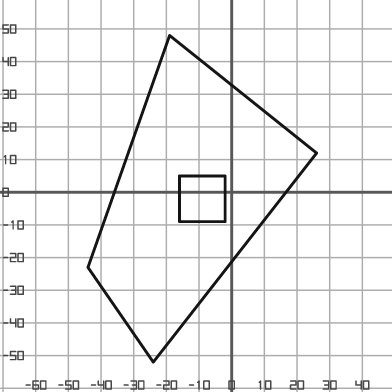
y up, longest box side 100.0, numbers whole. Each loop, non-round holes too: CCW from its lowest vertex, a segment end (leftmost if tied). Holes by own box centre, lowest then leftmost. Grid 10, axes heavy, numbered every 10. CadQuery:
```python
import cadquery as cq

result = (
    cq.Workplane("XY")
    .moveTo(-24.0, -52.0)
    .lineTo(26.0, 12.0)
    .lineTo(-19.0, 48.0)
    .lineTo(-44.0, -23.0)
    .close()
    .moveTo(-16.0, -9.0)
    .lineTo(-2.0, -9.0)
    .lineTo(-2.0, 5.0)
    .lineTo(-16.0, 5.0)
    .close()
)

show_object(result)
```